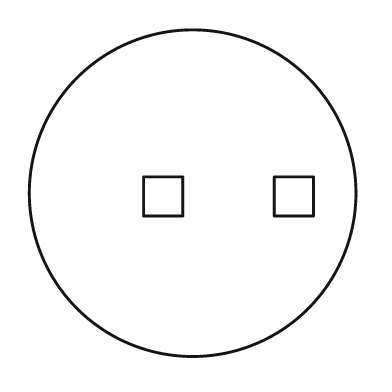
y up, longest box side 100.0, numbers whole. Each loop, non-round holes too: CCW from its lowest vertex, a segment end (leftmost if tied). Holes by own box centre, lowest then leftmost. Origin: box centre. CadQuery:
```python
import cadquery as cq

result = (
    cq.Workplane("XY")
    .moveTo(0.0, 0.0)
    .circle(50.0)
    .moveTo(-15.0, -7.0)
    .lineTo(-3.0, -7.0)
    .lineTo(-3.0, 5.0)
    .lineTo(-15.0, 5.0)
    .close()
    .moveTo(25.0, -7.0)
    .lineTo(37.0, -7.0)
    .lineTo(37.0, 5.0)
    .lineTo(25.0, 5.0)
    .close()
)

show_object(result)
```